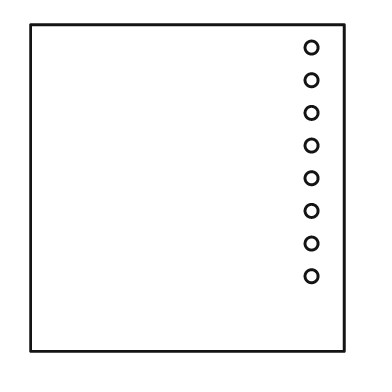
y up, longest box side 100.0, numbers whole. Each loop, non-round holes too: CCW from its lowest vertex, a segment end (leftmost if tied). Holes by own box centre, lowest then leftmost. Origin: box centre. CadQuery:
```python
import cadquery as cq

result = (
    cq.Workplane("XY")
    .moveTo(-48.0, -50.0)
    .lineTo(48.0, -50.0)
    .lineTo(48.0, 50.0)
    .lineTo(-48.0, 50.0)
    .close()
    .moveTo(38.0, -27.0)
    .circle(2.0)
    .moveTo(38.0, -17.0)
    .circle(2.0)
    .moveTo(38.0, -7.0)
    .circle(2.0)
    .moveTo(38.0, 3.0)
    .circle(2.0)
    .moveTo(38.0, 13.0)
    .circle(2.0)
    .moveTo(38.0, 23.0)
    .circle(2.0)
    .moveTo(38.0, 33.0)
    .circle(2.0)
    .moveTo(38.0, 43.0)
    .circle(2.0)
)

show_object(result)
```